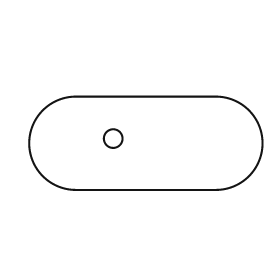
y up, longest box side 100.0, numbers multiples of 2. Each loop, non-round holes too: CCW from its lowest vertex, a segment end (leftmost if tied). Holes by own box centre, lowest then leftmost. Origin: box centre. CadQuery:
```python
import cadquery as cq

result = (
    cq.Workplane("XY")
    .moveTo(-30.0, -20.0)
    .lineTo(30.0, -20.0)
    .threePointArc((50.0, 0.0), (30.0, 20.0))
    .lineTo(-30.0, 20.0)
    .threePointArc((-50.0, 0.0), (-30.0, -20.0))
    .close()
    .moveTo(-14.0, 2.0)
    .circle(4.0)
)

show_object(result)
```